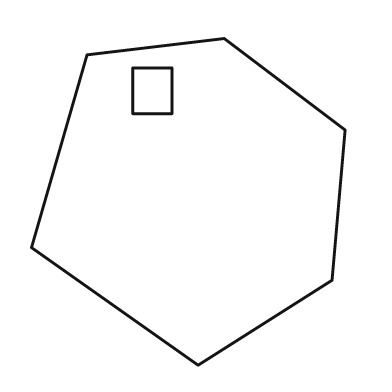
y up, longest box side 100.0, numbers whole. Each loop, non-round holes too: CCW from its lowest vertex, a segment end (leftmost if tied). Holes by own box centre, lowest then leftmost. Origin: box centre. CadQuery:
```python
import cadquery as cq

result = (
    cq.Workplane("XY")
    .moveTo(3.0, -50.0)
    .lineTo(44.0, -24.0)
    .lineTo(48.0, 22.0)
    .lineTo(11.0, 50.0)
    .lineTo(-31.0, 45.0)
    .lineTo(-48.0, -14.0)
    .close()
    .moveTo(-17.0, 27.0)
    .lineTo(-5.0, 27.0)
    .lineTo(-5.0, 41.0)
    .lineTo(-17.0, 41.0)
    .close()
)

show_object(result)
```